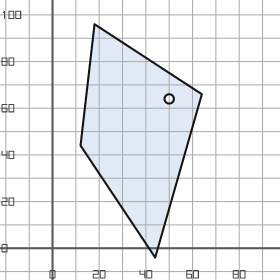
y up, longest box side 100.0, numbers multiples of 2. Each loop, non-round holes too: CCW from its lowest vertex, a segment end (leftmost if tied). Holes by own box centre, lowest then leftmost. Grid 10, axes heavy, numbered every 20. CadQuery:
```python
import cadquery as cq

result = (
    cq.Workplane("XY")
    .moveTo(44.0, -4.0)
    .lineTo(64.0, 66.0)
    .lineTo(18.0, 96.0)
    .lineTo(12.0, 44.0)
    .close()
    .moveTo(50.0, 64.0)
    .circle(2.0)
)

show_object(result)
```